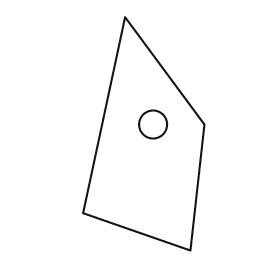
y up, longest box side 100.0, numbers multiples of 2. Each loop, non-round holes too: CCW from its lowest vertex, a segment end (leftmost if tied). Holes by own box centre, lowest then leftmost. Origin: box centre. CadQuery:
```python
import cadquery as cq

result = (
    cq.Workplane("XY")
    .moveTo(20.0, -50.0)
    .lineTo(26.0, 4.0)
    .lineTo(-8.0, 50.0)
    .lineTo(-26.0, -34.0)
    .close()
    .moveTo(4.0, 4.0)
    .circle(6.0)
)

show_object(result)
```